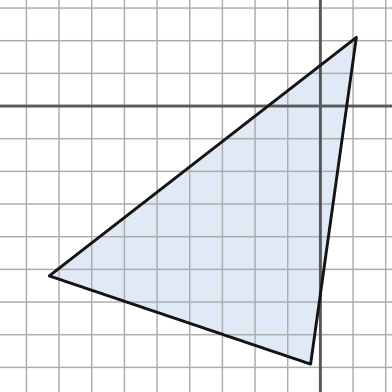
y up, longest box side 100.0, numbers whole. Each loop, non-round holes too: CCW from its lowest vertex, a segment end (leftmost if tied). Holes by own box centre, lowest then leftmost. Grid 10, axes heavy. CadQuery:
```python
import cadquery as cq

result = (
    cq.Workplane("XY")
    .moveTo(-3.0, -79.0)
    .lineTo(11.0, 21.0)
    .lineTo(-83.0, -52.0)
    .close()
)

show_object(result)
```